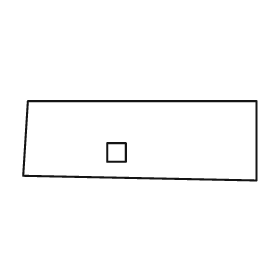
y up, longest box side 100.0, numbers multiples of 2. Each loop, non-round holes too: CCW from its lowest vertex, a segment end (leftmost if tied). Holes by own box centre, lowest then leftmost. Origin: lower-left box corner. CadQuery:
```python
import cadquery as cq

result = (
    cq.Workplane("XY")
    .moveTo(100.0, 0.0)
    .lineTo(100.0, 34.0)
    .lineTo(2.0, 34.0)
    .lineTo(0.0, 2.0)
    .close()
    .moveTo(36.0, 8.0)
    .lineTo(44.0, 8.0)
    .lineTo(44.0, 16.0)
    .lineTo(36.0, 16.0)
    .close()
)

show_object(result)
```